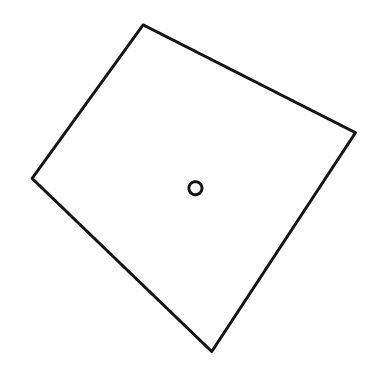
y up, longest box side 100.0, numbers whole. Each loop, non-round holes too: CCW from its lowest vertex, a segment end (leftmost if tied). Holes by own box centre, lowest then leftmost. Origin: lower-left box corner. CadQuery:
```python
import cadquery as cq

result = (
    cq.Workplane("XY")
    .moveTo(55.0, 0.0)
    .lineTo(99.0, 67.0)
    .lineTo(34.0, 100.0)
    .lineTo(0.0, 53.0)
    .close()
    .moveTo(50.0, 50.0)
    .circle(2.0)
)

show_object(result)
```